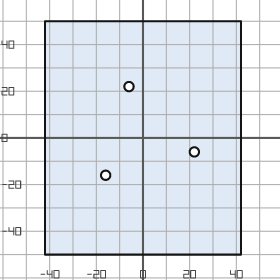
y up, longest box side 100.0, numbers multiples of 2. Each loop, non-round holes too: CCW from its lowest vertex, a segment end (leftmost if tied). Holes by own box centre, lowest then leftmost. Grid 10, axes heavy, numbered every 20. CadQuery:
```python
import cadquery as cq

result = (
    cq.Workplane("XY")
    .moveTo(-42.0, -50.0)
    .lineTo(42.0, -50.0)
    .lineTo(42.0, 50.0)
    .lineTo(-42.0, 50.0)
    .close()
    .moveTo(-16.0, -16.0)
    .circle(2.0)
    .moveTo(22.0, -6.0)
    .circle(2.0)
    .moveTo(-6.0, 22.0)
    .circle(2.0)
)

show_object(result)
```